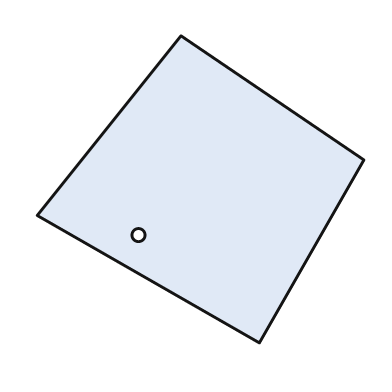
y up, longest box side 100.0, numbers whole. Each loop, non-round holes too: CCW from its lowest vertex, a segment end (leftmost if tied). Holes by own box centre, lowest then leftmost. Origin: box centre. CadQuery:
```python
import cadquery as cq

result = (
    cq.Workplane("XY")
    .moveTo(18.0, -47.0)
    .lineTo(50.0, 9.0)
    .lineTo(-6.0, 47.0)
    .lineTo(-50.0, -8.0)
    .close()
    .moveTo(-19.0, -14.0)
    .circle(2.0)
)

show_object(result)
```